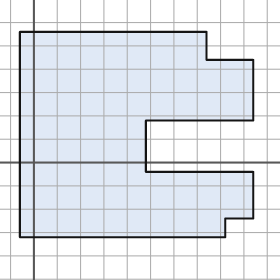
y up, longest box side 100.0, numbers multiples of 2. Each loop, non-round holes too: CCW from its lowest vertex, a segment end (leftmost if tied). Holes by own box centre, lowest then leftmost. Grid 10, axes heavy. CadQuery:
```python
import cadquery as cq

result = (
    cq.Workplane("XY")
    .moveTo(-6.0, -32.0)
    .lineTo(82.0, -32.0)
    .lineTo(82.0, -24.0)
    .lineTo(94.0, -24.0)
    .lineTo(94.0, -4.0)
    .lineTo(48.0, -4.0)
    .lineTo(48.0, 18.0)
    .lineTo(94.0, 18.0)
    .lineTo(94.0, 44.0)
    .lineTo(74.0, 44.0)
    .lineTo(74.0, 56.0)
    .lineTo(-6.0, 56.0)
    .close()
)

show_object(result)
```